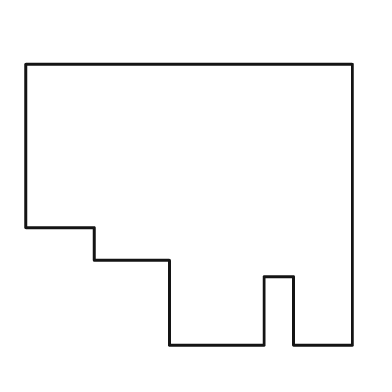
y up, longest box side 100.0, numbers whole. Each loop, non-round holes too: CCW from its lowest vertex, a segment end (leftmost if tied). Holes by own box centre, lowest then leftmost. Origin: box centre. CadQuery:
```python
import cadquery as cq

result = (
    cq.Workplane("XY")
    .moveTo(-6.0, -43.0)
    .lineTo(23.0, -43.0)
    .lineTo(23.0, -22.0)
    .lineTo(32.0, -22.0)
    .lineTo(32.0, -43.0)
    .lineTo(50.0, -43.0)
    .lineTo(50.0, 43.0)
    .lineTo(-50.0, 43.0)
    .lineTo(-50.0, -7.0)
    .lineTo(-29.0, -7.0)
    .lineTo(-29.0, -17.0)
    .lineTo(-6.0, -17.0)
    .close()
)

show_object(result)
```